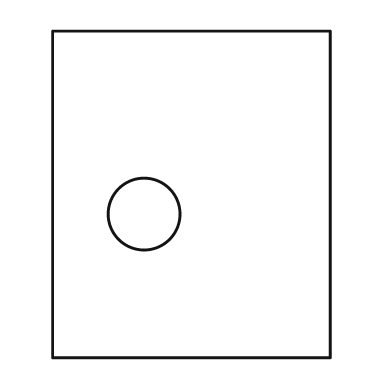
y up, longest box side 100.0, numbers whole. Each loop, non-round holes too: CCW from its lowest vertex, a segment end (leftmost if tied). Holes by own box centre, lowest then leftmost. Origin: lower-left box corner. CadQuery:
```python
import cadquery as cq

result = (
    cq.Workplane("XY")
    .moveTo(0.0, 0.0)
    .lineTo(85.0, 0.0)
    .lineTo(85.0, 100.0)
    .lineTo(0.0, 100.0)
    .close()
    .moveTo(28.0, 44.0)
    .circle(11.0)
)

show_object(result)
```